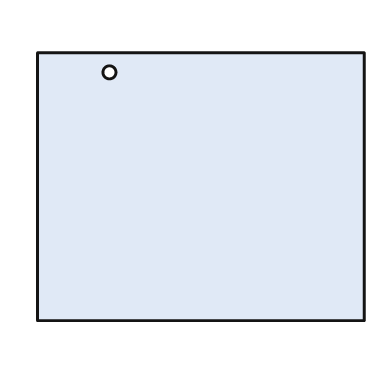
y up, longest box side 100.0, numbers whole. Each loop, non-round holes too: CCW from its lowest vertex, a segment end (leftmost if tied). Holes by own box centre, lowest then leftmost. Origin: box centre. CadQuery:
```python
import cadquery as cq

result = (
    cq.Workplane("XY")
    .moveTo(-50.0, -41.0)
    .lineTo(50.0, -41.0)
    .lineTo(50.0, 41.0)
    .lineTo(-50.0, 41.0)
    .close()
    .moveTo(-28.0, 35.0)
    .circle(2.0)
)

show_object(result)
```